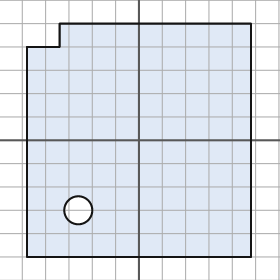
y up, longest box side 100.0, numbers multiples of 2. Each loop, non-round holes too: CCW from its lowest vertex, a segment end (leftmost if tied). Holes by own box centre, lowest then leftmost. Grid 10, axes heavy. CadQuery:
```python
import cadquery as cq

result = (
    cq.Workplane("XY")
    .moveTo(-48.0, -50.0)
    .lineTo(48.0, -50.0)
    .lineTo(48.0, 50.0)
    .lineTo(-34.0, 50.0)
    .lineTo(-34.0, 40.0)
    .lineTo(-48.0, 40.0)
    .close()
    .moveTo(-26.0, -30.0)
    .circle(6.0)
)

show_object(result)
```